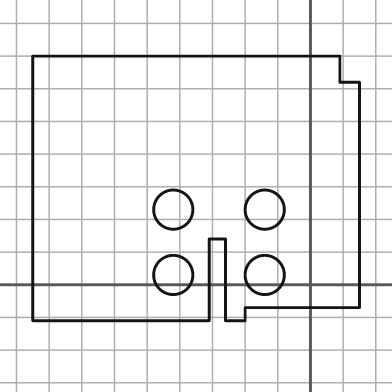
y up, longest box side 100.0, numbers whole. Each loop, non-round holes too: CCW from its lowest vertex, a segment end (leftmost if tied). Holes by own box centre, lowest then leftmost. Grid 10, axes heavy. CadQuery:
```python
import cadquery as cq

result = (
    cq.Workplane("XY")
    .moveTo(-85.0, -11.0)
    .lineTo(-31.0, -11.0)
    .lineTo(-31.0, 14.0)
    .lineTo(-26.0, 14.0)
    .lineTo(-26.0, -11.0)
    .lineTo(-20.0, -11.0)
    .lineTo(-20.0, -7.0)
    .lineTo(15.0, -7.0)
    .lineTo(15.0, 62.0)
    .lineTo(9.0, 62.0)
    .lineTo(9.0, 70.0)
    .lineTo(-85.0, 70.0)
    .close()
    .moveTo(-42.0, 3.0)
    .circle(6.0)
    .moveTo(-14.0, 3.0)
    .circle(6.0)
    .moveTo(-42.0, 23.0)
    .circle(6.0)
    .moveTo(-14.0, 23.0)
    .circle(6.0)
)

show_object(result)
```